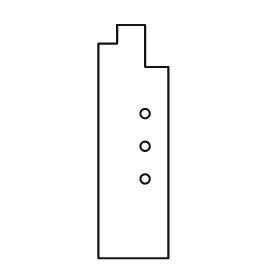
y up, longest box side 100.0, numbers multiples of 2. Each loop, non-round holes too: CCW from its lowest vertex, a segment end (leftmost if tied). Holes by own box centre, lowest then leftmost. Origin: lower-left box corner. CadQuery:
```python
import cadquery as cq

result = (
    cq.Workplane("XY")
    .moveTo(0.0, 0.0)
    .lineTo(30.0, 0.0)
    .lineTo(30.0, 82.0)
    .lineTo(20.0, 82.0)
    .lineTo(20.0, 100.0)
    .lineTo(8.0, 100.0)
    .lineTo(8.0, 92.0)
    .lineTo(0.0, 92.0)
    .close()
    .moveTo(20.0, 34.0)
    .circle(2.0)
    .moveTo(20.0, 48.0)
    .circle(2.0)
    .moveTo(20.0, 62.0)
    .circle(2.0)
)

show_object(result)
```